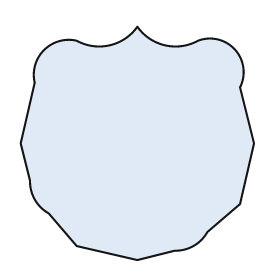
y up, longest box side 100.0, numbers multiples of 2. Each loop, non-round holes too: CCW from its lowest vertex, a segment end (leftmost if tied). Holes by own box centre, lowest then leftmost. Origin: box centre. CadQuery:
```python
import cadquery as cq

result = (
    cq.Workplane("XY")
    .moveTo(0.0, -50.0)
    .lineTo(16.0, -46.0)
    .threePointArc((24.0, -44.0), (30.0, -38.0))
    .lineTo(44.0, -26.0)
    .lineTo(50.0, 0.0)
    .lineTo(44.0, 24.0)
    .threePointArc((42.0, 40.0), (26.0, 44.0))
    .threePointArc((12.0, 42.0), (0.0, 50.0))
    .threePointArc((-12.0, 42.0), (-26.0, 44.0))
    .threePointArc((-40.0, 40.0), (-44.0, 26.0))
    .lineTo(-50.0, 0.0)
    .lineTo(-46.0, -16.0)
    .threePointArc((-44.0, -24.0), (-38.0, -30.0))
    .lineTo(-26.0, -44.0)
    .close()
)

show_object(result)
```